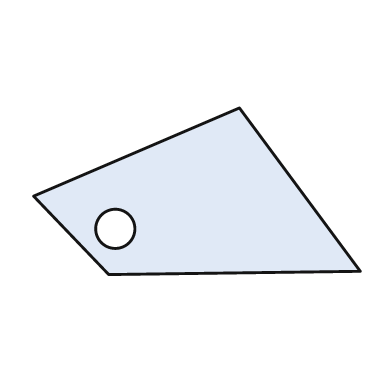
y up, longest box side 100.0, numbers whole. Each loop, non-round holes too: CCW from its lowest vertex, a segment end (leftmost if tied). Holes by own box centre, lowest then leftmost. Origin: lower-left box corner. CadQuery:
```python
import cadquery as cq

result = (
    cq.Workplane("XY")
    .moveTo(23.0, 0.0)
    .lineTo(100.0, 1.0)
    .lineTo(63.0, 51.0)
    .lineTo(0.0, 24.0)
    .close()
    .moveTo(25.0, 14.0)
    .circle(6.0)
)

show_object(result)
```